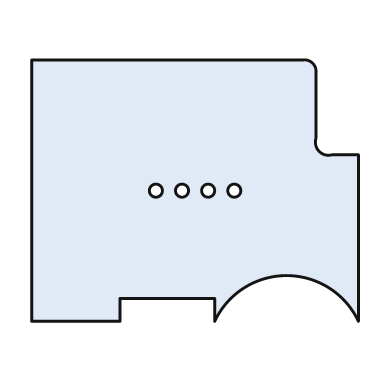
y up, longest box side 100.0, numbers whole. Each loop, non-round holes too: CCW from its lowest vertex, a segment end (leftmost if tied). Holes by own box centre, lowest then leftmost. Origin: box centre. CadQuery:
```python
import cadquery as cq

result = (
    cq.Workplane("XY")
    .moveTo(-50.0, -40.0)
    .lineTo(-23.0, -40.0)
    .lineTo(-23.0, -33.0)
    .lineTo(6.0, -33.0)
    .lineTo(6.0, -40.0)
    .threePointArc((28.0, -26.0), (50.0, -40.0))
    .lineTo(50.0, 11.0)
    .lineTo(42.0, 11.0)
    .threePointArc((38.0, 12.0), (37.0, 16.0))
    .lineTo(37.0, 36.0)
    .threePointArc((36.0, 39.0), (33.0, 40.0))
    .lineTo(-50.0, 40.0)
    .close()
    .moveTo(-12.0, 0.0)
    .circle(2.0)
    .moveTo(-4.0, 0.0)
    .circle(2.0)
    .moveTo(4.0, 0.0)
    .circle(2.0)
    .moveTo(12.0, 0.0)
    .circle(2.0)
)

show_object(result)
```